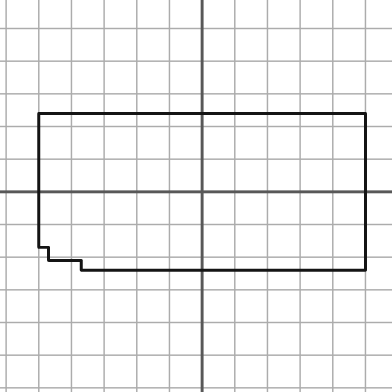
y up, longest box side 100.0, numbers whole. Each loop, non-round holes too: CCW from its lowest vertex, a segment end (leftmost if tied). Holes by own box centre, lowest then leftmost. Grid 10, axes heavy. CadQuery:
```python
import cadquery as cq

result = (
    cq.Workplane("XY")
    .moveTo(-37.0, -24.0)
    .lineTo(50.0, -24.0)
    .lineTo(50.0, 24.0)
    .lineTo(-50.0, 24.0)
    .lineTo(-50.0, -17.0)
    .lineTo(-47.0, -17.0)
    .lineTo(-47.0, -21.0)
    .lineTo(-37.0, -21.0)
    .close()
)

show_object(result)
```